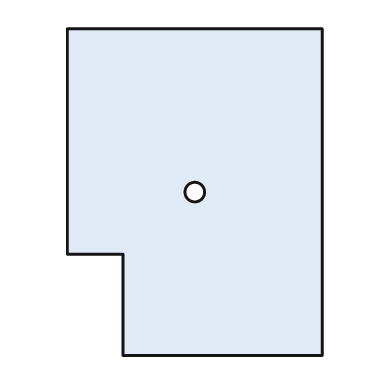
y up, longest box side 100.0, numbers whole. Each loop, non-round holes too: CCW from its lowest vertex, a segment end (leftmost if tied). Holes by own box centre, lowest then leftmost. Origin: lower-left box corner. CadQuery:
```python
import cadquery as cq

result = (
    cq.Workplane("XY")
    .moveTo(17.0, 0.0)
    .lineTo(78.0, 0.0)
    .lineTo(78.0, 100.0)
    .lineTo(0.0, 100.0)
    .lineTo(0.0, 31.0)
    .lineTo(17.0, 31.0)
    .close()
    .moveTo(39.0, 50.0)
    .circle(3.0)
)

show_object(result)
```